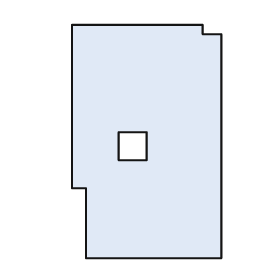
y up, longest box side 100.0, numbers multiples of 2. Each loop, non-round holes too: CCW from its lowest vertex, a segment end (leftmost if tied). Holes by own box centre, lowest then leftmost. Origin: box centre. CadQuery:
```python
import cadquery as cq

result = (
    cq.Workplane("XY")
    .moveTo(-26.0, -50.0)
    .lineTo(32.0, -50.0)
    .lineTo(32.0, 46.0)
    .lineTo(24.0, 46.0)
    .lineTo(24.0, 50.0)
    .lineTo(-32.0, 50.0)
    .lineTo(-32.0, -20.0)
    .lineTo(-26.0, -20.0)
    .close()
    .moveTo(-12.0, -8.0)
    .lineTo(0.0, -8.0)
    .lineTo(0.0, 4.0)
    .lineTo(-12.0, 4.0)
    .close()
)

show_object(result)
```